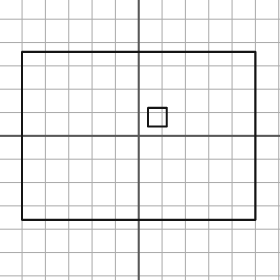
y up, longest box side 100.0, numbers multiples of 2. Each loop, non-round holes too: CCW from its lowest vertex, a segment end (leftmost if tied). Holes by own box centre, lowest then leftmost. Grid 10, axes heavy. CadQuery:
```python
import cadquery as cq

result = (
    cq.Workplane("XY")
    .moveTo(-50.0, -36.0)
    .lineTo(50.0, -36.0)
    .lineTo(50.0, 36.0)
    .lineTo(-50.0, 36.0)
    .close()
    .moveTo(4.0, 4.0)
    .lineTo(12.0, 4.0)
    .lineTo(12.0, 12.0)
    .lineTo(4.0, 12.0)
    .close()
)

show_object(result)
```